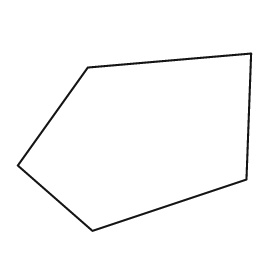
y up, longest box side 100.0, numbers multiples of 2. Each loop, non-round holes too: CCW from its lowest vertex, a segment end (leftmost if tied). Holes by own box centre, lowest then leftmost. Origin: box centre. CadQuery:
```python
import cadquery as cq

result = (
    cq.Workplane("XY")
    .moveTo(-18.0, -38.0)
    .lineTo(48.0, -16.0)
    .lineTo(50.0, 38.0)
    .lineTo(-20.0, 32.0)
    .lineTo(-50.0, -10.0)
    .close()
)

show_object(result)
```